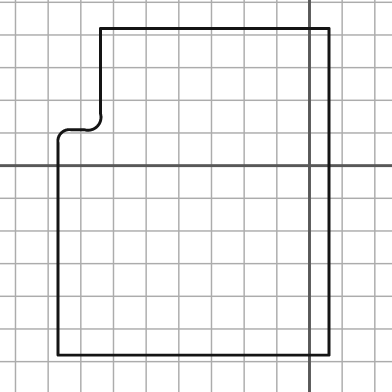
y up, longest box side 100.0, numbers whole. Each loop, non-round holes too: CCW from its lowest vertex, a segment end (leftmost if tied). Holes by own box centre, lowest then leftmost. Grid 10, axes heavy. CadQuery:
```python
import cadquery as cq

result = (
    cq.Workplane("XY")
    .moveTo(-77.0, -58.0)
    .lineTo(6.0, -58.0)
    .lineTo(6.0, 42.0)
    .lineTo(-64.0, 42.0)
    .lineTo(-64.0, 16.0)
    .threePointArc((-65.0, 12.0), (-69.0, 11.0))
    .lineTo(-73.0, 11.0)
    .threePointArc((-76.0, 10.0), (-77.0, 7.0))
    .close()
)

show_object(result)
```